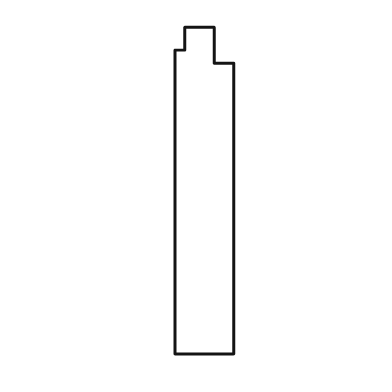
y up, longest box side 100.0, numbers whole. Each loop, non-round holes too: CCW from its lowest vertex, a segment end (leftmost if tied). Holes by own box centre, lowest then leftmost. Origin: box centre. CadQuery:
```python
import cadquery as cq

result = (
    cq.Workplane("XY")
    .moveTo(-9.0, -50.0)
    .lineTo(9.0, -50.0)
    .lineTo(9.0, 39.0)
    .lineTo(3.0, 39.0)
    .lineTo(3.0, 50.0)
    .lineTo(-6.0, 50.0)
    .lineTo(-6.0, 43.0)
    .lineTo(-9.0, 43.0)
    .close()
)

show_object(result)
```